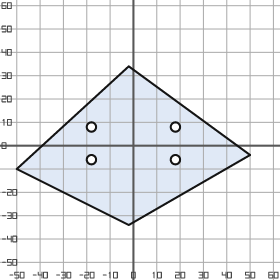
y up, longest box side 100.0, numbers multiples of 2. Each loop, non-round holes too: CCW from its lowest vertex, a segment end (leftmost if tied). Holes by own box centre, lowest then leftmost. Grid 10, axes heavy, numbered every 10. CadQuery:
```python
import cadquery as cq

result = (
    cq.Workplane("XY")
    .moveTo(-2.0, -34.0)
    .lineTo(50.0, -4.0)
    .lineTo(-2.0, 34.0)
    .lineTo(-50.0, -10.0)
    .close()
    .moveTo(-18.0, -6.0)
    .circle(2.0)
    .moveTo(18.0, -6.0)
    .circle(2.0)
    .moveTo(-18.0, 8.0)
    .circle(2.0)
    .moveTo(18.0, 8.0)
    .circle(2.0)
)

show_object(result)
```